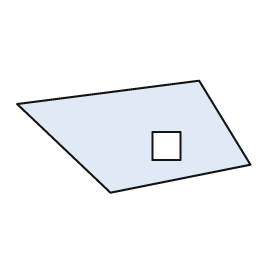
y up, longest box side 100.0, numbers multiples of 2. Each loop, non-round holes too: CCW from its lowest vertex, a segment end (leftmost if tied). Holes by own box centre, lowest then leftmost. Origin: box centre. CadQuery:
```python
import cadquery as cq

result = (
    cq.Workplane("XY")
    .moveTo(-10.0, -24.0)
    .lineTo(50.0, -12.0)
    .lineTo(28.0, 24.0)
    .lineTo(-50.0, 14.0)
    .close()
    .moveTo(8.0, -10.0)
    .lineTo(20.0, -10.0)
    .lineTo(20.0, 2.0)
    .lineTo(8.0, 2.0)
    .close()
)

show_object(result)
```